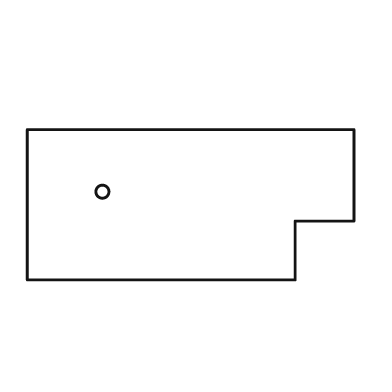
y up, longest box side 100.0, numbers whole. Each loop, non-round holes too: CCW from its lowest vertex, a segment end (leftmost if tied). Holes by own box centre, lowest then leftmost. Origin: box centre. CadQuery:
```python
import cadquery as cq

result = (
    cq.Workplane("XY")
    .moveTo(-50.0, -23.0)
    .lineTo(32.0, -23.0)
    .lineTo(32.0, -5.0)
    .lineTo(50.0, -5.0)
    .lineTo(50.0, 23.0)
    .lineTo(-50.0, 23.0)
    .close()
    .moveTo(-27.0, 4.0)
    .circle(2.0)
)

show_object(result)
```